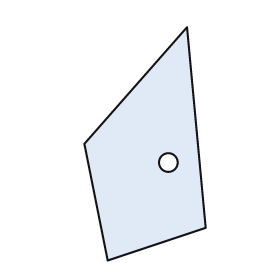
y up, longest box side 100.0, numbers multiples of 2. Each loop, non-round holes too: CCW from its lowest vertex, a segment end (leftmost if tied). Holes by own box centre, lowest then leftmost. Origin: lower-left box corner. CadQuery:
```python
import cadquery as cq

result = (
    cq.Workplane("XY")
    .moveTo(10.0, 0.0)
    .lineTo(52.0, 14.0)
    .lineTo(44.0, 100.0)
    .lineTo(0.0, 50.0)
    .close()
    .moveTo(36.0, 42.0)
    .circle(4.0)
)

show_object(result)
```